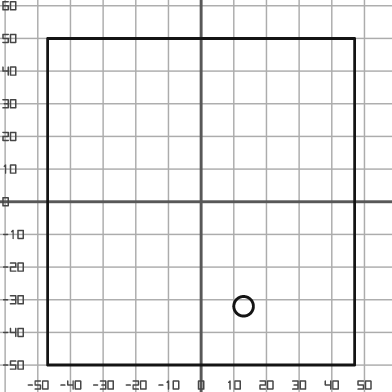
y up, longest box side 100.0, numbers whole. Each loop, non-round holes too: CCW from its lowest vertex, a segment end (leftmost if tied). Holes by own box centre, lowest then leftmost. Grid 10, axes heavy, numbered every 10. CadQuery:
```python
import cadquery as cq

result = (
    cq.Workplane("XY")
    .moveTo(-47.0, -50.0)
    .lineTo(47.0, -50.0)
    .lineTo(47.0, 50.0)
    .lineTo(-47.0, 50.0)
    .close()
    .moveTo(13.0, -32.0)
    .circle(3.0)
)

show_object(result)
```